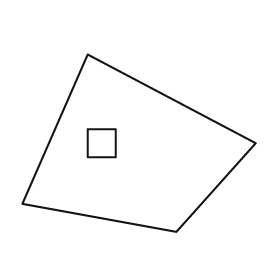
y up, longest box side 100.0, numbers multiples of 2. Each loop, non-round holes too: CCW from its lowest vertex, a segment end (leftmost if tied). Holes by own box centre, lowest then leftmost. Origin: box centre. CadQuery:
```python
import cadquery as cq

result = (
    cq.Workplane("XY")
    .moveTo(16.0, -38.0)
    .lineTo(50.0, 0.0)
    .lineTo(-22.0, 38.0)
    .lineTo(-50.0, -26.0)
    .close()
    .moveTo(-22.0, -6.0)
    .lineTo(-10.0, -6.0)
    .lineTo(-10.0, 6.0)
    .lineTo(-22.0, 6.0)
    .close()
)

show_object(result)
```